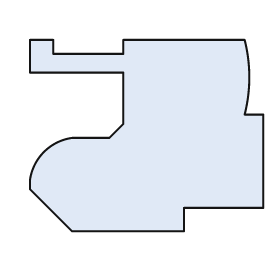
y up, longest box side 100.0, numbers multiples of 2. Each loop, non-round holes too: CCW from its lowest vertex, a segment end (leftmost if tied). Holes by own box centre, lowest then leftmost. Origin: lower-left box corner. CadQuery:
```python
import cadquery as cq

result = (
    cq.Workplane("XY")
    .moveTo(18.0, 0.0)
    .lineTo(66.0, 0.0)
    .lineTo(66.0, 10.0)
    .lineTo(100.0, 10.0)
    .lineTo(100.0, 50.0)
    .lineTo(92.0, 50.0)
    .threePointArc((94.0, 66.0), (92.0, 82.0))
    .lineTo(40.0, 82.0)
    .lineTo(40.0, 76.0)
    .lineTo(10.0, 76.0)
    .lineTo(10.0, 82.0)
    .lineTo(0.0, 82.0)
    .lineTo(0.0, 68.0)
    .lineTo(40.0, 68.0)
    .lineTo(40.0, 46.0)
    .lineTo(34.0, 40.0)
    .lineTo(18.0, 40.0)
    .threePointArc((6.0, 34.0), (0.0, 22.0))
    .lineTo(0.0, 18.0)
    .close()
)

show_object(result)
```